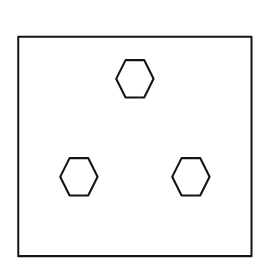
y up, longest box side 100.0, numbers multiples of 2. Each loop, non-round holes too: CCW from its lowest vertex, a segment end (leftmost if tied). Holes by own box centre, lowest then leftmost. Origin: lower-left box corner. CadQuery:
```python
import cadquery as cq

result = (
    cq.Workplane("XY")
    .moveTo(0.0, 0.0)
    .lineTo(100.0, 0.0)
    .lineTo(100.0, 94.0)
    .lineTo(0.0, 94.0)
    .close()
    .moveTo(22.0, 26.0)
    .lineTo(30.0, 26.0)
    .lineTo(34.0, 34.0)
    .lineTo(30.0, 42.0)
    .lineTo(22.0, 42.0)
    .lineTo(18.0, 34.0)
    .close()
    .moveTo(70.0, 26.0)
    .lineTo(78.0, 26.0)
    .lineTo(82.0, 34.0)
    .lineTo(78.0, 42.0)
    .lineTo(70.0, 42.0)
    .lineTo(66.0, 34.0)
    .close()
    .moveTo(46.0, 68.0)
    .lineTo(54.0, 68.0)
    .lineTo(58.0, 76.0)
    .lineTo(54.0, 84.0)
    .lineTo(46.0, 84.0)
    .lineTo(42.0, 76.0)
    .close()
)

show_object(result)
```